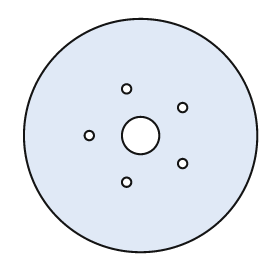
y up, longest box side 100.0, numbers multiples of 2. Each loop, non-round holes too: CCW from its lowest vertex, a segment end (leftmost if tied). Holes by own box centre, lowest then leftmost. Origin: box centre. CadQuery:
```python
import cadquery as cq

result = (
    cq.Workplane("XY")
    .moveTo(0.0, 0.0)
    .circle(50.0)
    .moveTo(-6.0, -20.0)
    .circle(2.0)
    .moveTo(18.0, -12.0)
    .circle(2.0)
    .moveTo(-22.0, 0.0)
    .circle(2.0)
    .moveTo(0.0, 0.0)
    .circle(8.0)
    .moveTo(18.0, 12.0)
    .circle(2.0)
    .moveTo(-6.0, 20.0)
    .circle(2.0)
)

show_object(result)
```